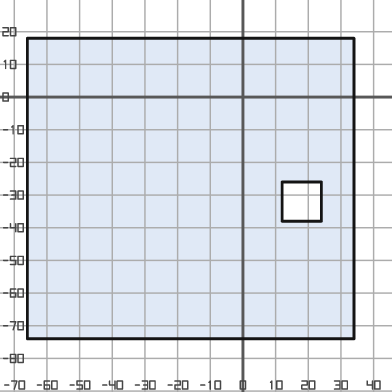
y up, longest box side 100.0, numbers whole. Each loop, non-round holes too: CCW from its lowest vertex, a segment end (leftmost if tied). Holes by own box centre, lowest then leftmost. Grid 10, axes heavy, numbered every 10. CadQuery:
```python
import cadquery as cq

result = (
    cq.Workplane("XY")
    .moveTo(-66.0, -74.0)
    .lineTo(34.0, -74.0)
    .lineTo(34.0, 18.0)
    .lineTo(-66.0, 18.0)
    .close()
    .moveTo(12.0, -38.0)
    .lineTo(24.0, -38.0)
    .lineTo(24.0, -26.0)
    .lineTo(12.0, -26.0)
    .close()
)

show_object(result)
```